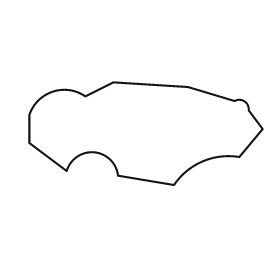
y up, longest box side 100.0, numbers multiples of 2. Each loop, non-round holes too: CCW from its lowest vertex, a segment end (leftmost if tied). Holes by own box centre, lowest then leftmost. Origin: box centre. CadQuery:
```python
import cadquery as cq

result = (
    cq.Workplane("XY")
    .moveTo(12.0, -22.0)
    .threePointArc((24.0, -12.0), (40.0, -10.0))
    .lineTo(50.0, 2.0)
    .lineTo(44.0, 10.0)
    .threePointArc((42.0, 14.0), (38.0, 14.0))
    .lineTo(18.0, 20.0)
    .lineTo(-14.0, 22.0)
    .lineTo(-26.0, 16.0)
    .threePointArc((-40.0, 18.0), (-50.0, 8.0))
    .lineTo(-50.0, -4.0)
    .lineTo(-34.0, -16.0)
    .threePointArc((-22.0, -8.0), (-12.0, -18.0))
    .close()
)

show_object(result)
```